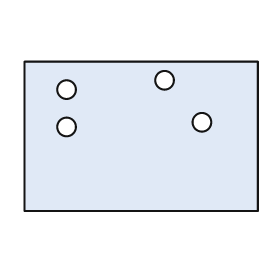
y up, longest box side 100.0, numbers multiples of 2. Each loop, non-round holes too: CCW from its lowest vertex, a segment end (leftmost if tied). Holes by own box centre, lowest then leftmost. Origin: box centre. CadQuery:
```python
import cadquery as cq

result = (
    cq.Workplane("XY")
    .moveTo(-50.0, -32.0)
    .lineTo(50.0, -32.0)
    .lineTo(50.0, 32.0)
    .lineTo(-50.0, 32.0)
    .close()
    .moveTo(-32.0, 4.0)
    .circle(4.0)
    .moveTo(26.0, 6.0)
    .circle(4.0)
    .moveTo(-32.0, 20.0)
    .circle(4.0)
    .moveTo(10.0, 24.0)
    .circle(4.0)
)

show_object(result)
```